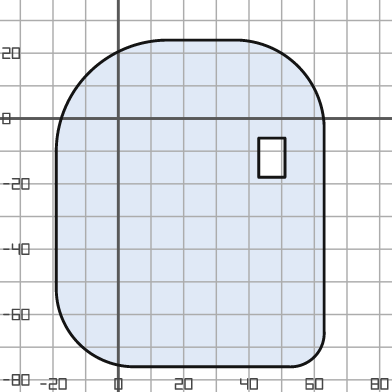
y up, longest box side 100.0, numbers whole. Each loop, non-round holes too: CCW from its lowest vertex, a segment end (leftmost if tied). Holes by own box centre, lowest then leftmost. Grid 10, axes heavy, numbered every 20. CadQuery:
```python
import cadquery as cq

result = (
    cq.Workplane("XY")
    .moveTo(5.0, -76.0)
    .lineTo(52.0, -76.0)
    .threePointArc((60.0, -73.0), (63.0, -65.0))
    .lineTo(63.0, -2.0)
    .threePointArc((55.0, 16.0), (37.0, 24.0))
    .lineTo(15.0, 24.0)
    .threePointArc((-9.0, 14.0), (-19.0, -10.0))
    .lineTo(-19.0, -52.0)
    .threePointArc((-12.0, -69.0), (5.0, -76.0))
    .close()
    .moveTo(43.0, -18.0)
    .lineTo(51.0, -18.0)
    .lineTo(51.0, -6.0)
    .lineTo(43.0, -6.0)
    .close()
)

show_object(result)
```